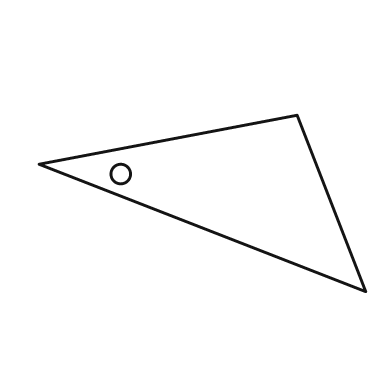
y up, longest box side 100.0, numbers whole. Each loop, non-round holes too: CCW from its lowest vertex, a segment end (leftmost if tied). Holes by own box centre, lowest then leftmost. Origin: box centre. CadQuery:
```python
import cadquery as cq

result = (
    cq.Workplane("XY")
    .moveTo(50.0, -27.0)
    .lineTo(29.0, 27.0)
    .lineTo(-50.0, 12.0)
    .close()
    .moveTo(-25.0, 9.0)
    .circle(3.0)
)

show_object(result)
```